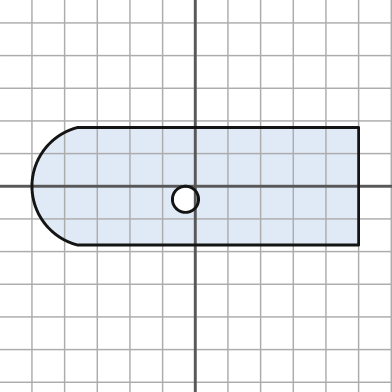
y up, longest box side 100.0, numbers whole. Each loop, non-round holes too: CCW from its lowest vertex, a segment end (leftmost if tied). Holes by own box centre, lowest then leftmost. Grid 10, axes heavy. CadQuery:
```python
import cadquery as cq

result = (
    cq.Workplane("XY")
    .moveTo(-36.0, -18.0)
    .lineTo(50.0, -18.0)
    .lineTo(50.0, 18.0)
    .lineTo(-36.0, 18.0)
    .threePointArc((-50.0, 0.0), (-36.0, -18.0))
    .close()
    .moveTo(-3.0, -4.0)
    .circle(4.0)
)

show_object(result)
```